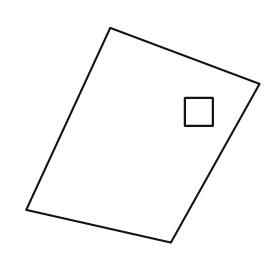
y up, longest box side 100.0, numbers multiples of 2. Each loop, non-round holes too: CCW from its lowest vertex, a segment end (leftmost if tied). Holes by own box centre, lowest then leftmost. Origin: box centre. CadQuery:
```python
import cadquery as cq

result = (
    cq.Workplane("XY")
    .moveTo(12.0, -46.0)
    .lineTo(50.0, 22.0)
    .lineTo(-14.0, 46.0)
    .lineTo(-50.0, -32.0)
    .close()
    .moveTo(18.0, 4.0)
    .lineTo(30.0, 4.0)
    .lineTo(30.0, 16.0)
    .lineTo(18.0, 16.0)
    .close()
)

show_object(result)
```